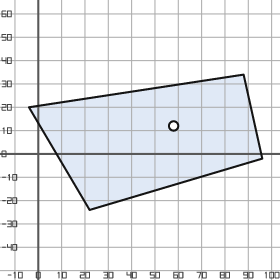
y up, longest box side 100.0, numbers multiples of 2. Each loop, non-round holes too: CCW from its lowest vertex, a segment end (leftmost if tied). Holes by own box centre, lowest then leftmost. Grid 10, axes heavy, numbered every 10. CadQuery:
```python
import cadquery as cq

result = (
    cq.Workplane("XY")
    .moveTo(22.0, -24.0)
    .lineTo(96.0, -2.0)
    .lineTo(88.0, 34.0)
    .lineTo(-4.0, 20.0)
    .close()
    .moveTo(58.0, 12.0)
    .circle(2.0)
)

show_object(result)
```